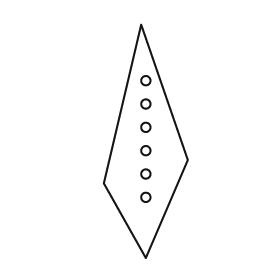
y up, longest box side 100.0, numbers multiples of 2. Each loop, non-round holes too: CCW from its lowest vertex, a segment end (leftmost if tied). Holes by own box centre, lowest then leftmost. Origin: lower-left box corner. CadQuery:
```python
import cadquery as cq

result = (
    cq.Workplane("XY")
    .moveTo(18.0, 0.0)
    .lineTo(36.0, 42.0)
    .lineTo(16.0, 100.0)
    .lineTo(0.0, 32.0)
    .close()
    .moveTo(18.0, 26.0)
    .circle(2.0)
    .moveTo(18.0, 36.0)
    .circle(2.0)
    .moveTo(18.0, 46.0)
    .circle(2.0)
    .moveTo(18.0, 56.0)
    .circle(2.0)
    .moveTo(18.0, 66.0)
    .circle(2.0)
    .moveTo(18.0, 76.0)
    .circle(2.0)
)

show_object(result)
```